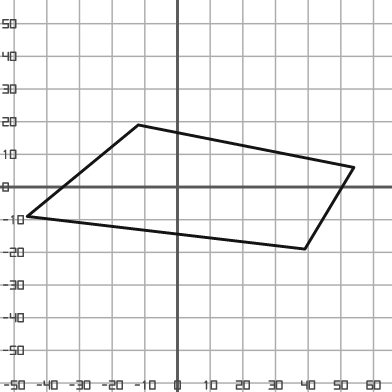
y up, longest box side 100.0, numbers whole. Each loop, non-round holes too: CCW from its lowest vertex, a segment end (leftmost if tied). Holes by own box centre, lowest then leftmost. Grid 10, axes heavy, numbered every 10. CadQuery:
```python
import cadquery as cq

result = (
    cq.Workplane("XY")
    .moveTo(39.0, -19.0)
    .lineTo(54.0, 6.0)
    .lineTo(-12.0, 19.0)
    .lineTo(-46.0, -9.0)
    .close()
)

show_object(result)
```